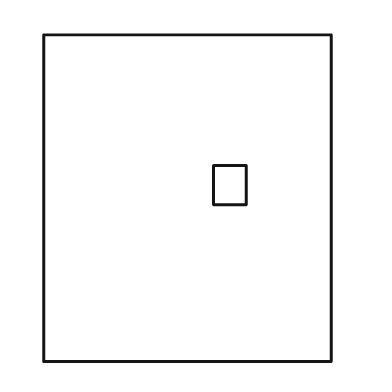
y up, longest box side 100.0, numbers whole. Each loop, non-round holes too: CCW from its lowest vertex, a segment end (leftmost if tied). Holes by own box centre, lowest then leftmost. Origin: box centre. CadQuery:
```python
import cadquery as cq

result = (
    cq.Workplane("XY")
    .moveTo(-44.0, -50.0)
    .lineTo(44.0, -50.0)
    .lineTo(44.0, 50.0)
    .lineTo(-44.0, 50.0)
    .close()
    .moveTo(8.0, -2.0)
    .lineTo(18.0, -2.0)
    .lineTo(18.0, 10.0)
    .lineTo(8.0, 10.0)
    .close()
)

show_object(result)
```